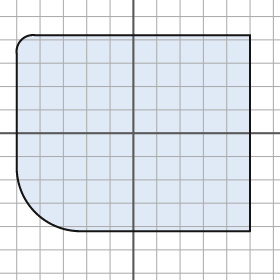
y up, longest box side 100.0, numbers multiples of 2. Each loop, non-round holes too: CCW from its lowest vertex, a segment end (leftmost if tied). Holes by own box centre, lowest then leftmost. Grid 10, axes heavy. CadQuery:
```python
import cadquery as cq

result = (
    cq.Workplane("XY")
    .moveTo(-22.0, -42.0)
    .lineTo(50.0, -42.0)
    .lineTo(50.0, 42.0)
    .lineTo(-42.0, 42.0)
    .threePointArc((-48.0, 40.0), (-50.0, 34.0))
    .lineTo(-50.0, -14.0)
    .threePointArc((-42.0, -34.0), (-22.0, -42.0))
    .close()
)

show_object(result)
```